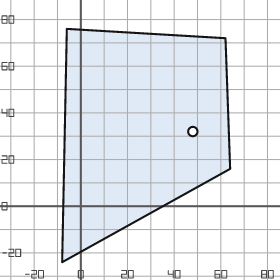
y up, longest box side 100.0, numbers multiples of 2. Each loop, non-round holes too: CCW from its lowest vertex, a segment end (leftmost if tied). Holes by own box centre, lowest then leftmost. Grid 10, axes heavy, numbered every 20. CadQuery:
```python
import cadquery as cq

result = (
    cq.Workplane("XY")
    .moveTo(-8.0, -24.0)
    .lineTo(64.0, 16.0)
    .lineTo(62.0, 72.0)
    .lineTo(-6.0, 76.0)
    .close()
    .moveTo(48.0, 32.0)
    .circle(2.0)
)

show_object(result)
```